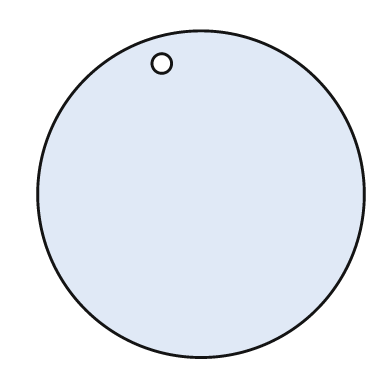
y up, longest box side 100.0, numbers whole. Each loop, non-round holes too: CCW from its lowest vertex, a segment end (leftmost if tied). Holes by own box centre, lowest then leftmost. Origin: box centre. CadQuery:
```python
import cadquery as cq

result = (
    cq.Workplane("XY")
    .moveTo(0.0, 0.0)
    .circle(50.0)
    .moveTo(-12.0, 40.0)
    .circle(3.0)
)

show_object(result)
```